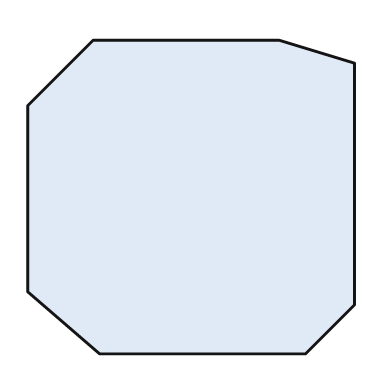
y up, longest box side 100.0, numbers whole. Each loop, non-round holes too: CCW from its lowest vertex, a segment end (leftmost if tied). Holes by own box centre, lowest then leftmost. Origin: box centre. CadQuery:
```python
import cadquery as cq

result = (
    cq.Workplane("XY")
    .moveTo(-28.0, -48.0)
    .lineTo(35.0, -48.0)
    .lineTo(50.0, -33.0)
    .lineTo(50.0, 41.0)
    .lineTo(27.0, 48.0)
    .lineTo(-30.0, 48.0)
    .lineTo(-50.0, 28.0)
    .lineTo(-50.0, -29.0)
    .close()
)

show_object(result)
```